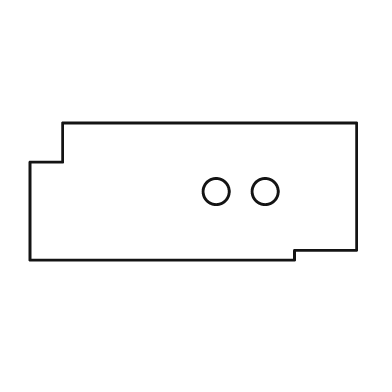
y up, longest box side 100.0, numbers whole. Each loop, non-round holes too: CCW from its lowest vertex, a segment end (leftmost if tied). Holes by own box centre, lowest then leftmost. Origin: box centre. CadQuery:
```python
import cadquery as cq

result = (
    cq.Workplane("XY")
    .moveTo(-50.0, -21.0)
    .lineTo(31.0, -21.0)
    .lineTo(31.0, -18.0)
    .lineTo(50.0, -18.0)
    .lineTo(50.0, 21.0)
    .lineTo(-40.0, 21.0)
    .lineTo(-40.0, 9.0)
    .lineTo(-50.0, 9.0)
    .close()
    .moveTo(7.0, 0.0)
    .circle(4.0)
    .moveTo(22.0, 0.0)
    .circle(4.0)
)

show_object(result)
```